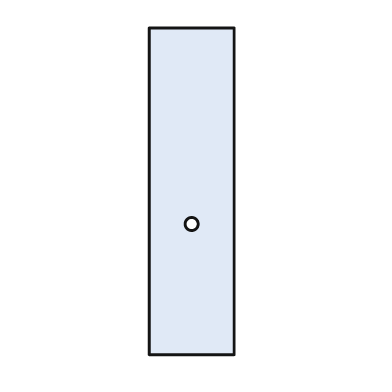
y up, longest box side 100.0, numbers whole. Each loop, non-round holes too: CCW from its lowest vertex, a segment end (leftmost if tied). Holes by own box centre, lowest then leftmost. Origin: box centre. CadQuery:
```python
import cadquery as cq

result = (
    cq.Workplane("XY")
    .moveTo(-13.0, -50.0)
    .lineTo(13.0, -50.0)
    .lineTo(13.0, 50.0)
    .lineTo(-13.0, 50.0)
    .close()
    .moveTo(0.0, -10.0)
    .circle(2.0)
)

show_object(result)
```